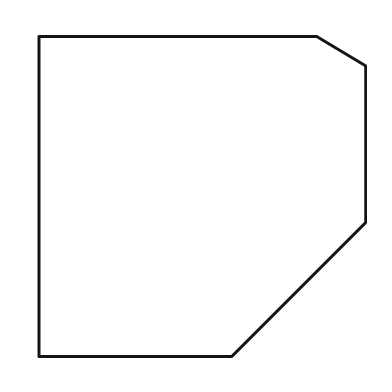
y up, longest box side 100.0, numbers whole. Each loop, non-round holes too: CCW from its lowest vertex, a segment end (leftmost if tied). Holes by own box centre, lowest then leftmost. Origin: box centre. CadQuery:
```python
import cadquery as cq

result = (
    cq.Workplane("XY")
    .moveTo(-50.0, -49.0)
    .lineTo(9.0, -49.0)
    .lineTo(50.0, -8.0)
    .lineTo(50.0, 40.0)
    .lineTo(35.0, 49.0)
    .lineTo(-50.0, 49.0)
    .close()
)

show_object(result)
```